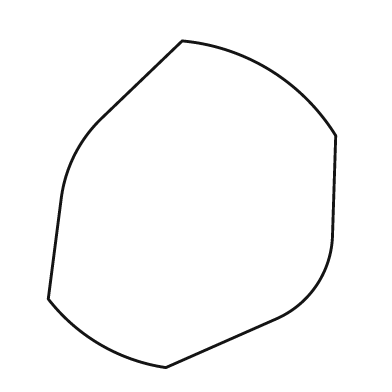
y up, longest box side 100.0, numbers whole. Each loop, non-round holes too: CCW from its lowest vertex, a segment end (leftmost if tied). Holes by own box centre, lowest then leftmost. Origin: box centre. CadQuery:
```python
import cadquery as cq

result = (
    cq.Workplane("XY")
    .moveTo(-8.0, -50.0)
    .lineTo(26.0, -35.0)
    .threePointArc((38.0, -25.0), (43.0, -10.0))
    .lineTo(44.0, 21.0)
    .threePointArc((24.0, 41.0), (-3.0, 50.0))
    .lineTo(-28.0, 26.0)
    .threePointArc((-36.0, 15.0), (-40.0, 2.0))
    .lineTo(-44.0, -29.0)
    .threePointArc((-28.0, -43.0), (-8.0, -50.0))
    .close()
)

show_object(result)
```